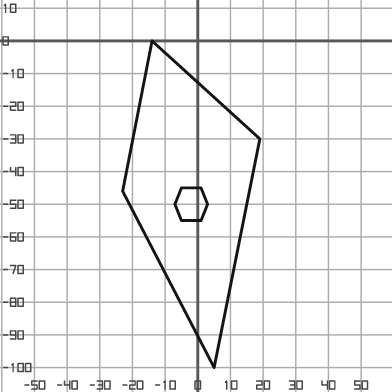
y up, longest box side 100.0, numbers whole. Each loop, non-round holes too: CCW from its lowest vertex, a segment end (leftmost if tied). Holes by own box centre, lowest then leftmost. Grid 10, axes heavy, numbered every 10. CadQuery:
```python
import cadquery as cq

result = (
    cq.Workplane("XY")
    .moveTo(5.0, -100.0)
    .lineTo(19.0, -30.0)
    .lineTo(-14.0, 0.0)
    .lineTo(-23.0, -46.0)
    .close()
    .moveTo(-5.0, -55.0)
    .lineTo(1.0, -55.0)
    .lineTo(3.0, -50.0)
    .lineTo(1.0, -45.0)
    .lineTo(-5.0, -45.0)
    .lineTo(-7.0, -50.0)
    .close()
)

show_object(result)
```